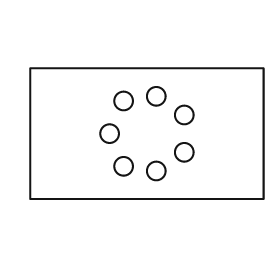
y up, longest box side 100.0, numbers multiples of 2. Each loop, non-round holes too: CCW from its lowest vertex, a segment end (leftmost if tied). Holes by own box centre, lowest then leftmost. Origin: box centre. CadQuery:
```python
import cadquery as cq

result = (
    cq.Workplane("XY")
    .moveTo(-50.0, -28.0)
    .lineTo(50.0, -28.0)
    .lineTo(50.0, 28.0)
    .lineTo(-50.0, 28.0)
    .close()
    .moveTo(4.0, -16.0)
    .circle(4.0)
    .moveTo(-10.0, -14.0)
    .circle(4.0)
    .moveTo(16.0, -8.0)
    .circle(4.0)
    .moveTo(-16.0, 0.0)
    .circle(4.0)
    .moveTo(16.0, 8.0)
    .circle(4.0)
    .moveTo(-10.0, 14.0)
    .circle(4.0)
    .moveTo(4.0, 16.0)
    .circle(4.0)
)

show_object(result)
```